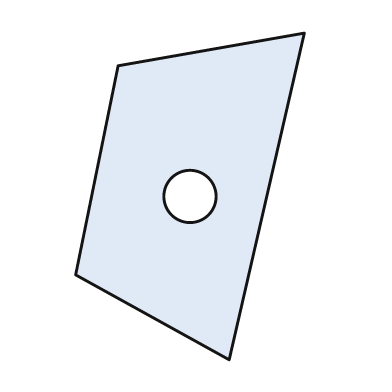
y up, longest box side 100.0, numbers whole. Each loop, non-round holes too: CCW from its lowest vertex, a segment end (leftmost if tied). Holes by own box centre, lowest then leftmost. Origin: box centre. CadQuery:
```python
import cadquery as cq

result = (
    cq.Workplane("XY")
    .moveTo(12.0, -50.0)
    .lineTo(35.0, 50.0)
    .lineTo(-22.0, 40.0)
    .lineTo(-35.0, -24.0)
    .close()
    .moveTo(0.0, 0.0)
    .circle(8.0)
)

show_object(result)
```